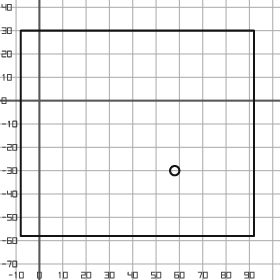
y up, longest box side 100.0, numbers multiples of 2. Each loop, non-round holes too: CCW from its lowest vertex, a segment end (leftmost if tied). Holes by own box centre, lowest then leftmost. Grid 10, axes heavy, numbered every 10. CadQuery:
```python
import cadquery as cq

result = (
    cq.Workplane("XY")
    .moveTo(-8.0, -58.0)
    .lineTo(92.0, -58.0)
    .lineTo(92.0, 30.0)
    .lineTo(-8.0, 30.0)
    .close()
    .moveTo(58.0, -30.0)
    .circle(2.0)
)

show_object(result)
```